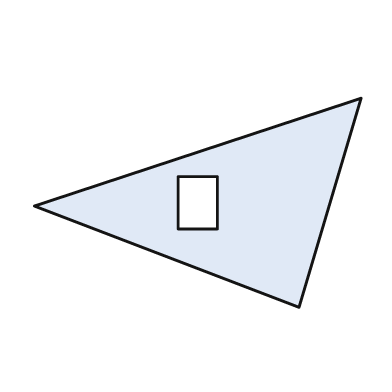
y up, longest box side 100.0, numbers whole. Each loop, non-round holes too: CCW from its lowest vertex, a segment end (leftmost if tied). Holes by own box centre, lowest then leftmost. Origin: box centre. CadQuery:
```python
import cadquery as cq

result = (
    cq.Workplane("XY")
    .moveTo(31.0, -32.0)
    .lineTo(50.0, 32.0)
    .lineTo(-50.0, -1.0)
    .close()
    .moveTo(-6.0, -8.0)
    .lineTo(6.0, -8.0)
    .lineTo(6.0, 8.0)
    .lineTo(-6.0, 8.0)
    .close()
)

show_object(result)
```